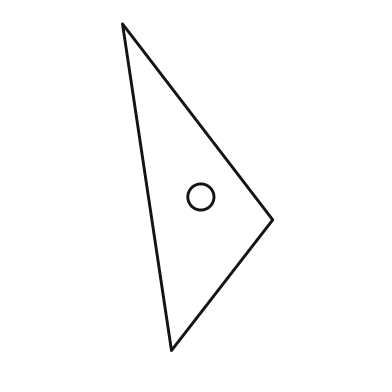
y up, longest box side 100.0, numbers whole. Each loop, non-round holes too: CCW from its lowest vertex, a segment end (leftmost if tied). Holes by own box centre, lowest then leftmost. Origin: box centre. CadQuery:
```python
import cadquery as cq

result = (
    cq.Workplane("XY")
    .moveTo(-8.0, -50.0)
    .lineTo(23.0, -10.0)
    .lineTo(-23.0, 50.0)
    .close()
    .moveTo(1.0, -3.0)
    .circle(4.0)
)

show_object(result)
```